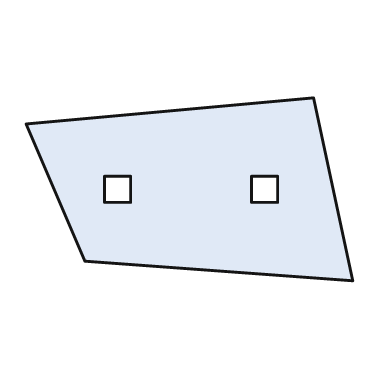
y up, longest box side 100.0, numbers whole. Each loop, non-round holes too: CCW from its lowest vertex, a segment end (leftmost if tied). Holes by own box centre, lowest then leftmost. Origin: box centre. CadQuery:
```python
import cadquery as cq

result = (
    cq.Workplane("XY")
    .moveTo(50.0, -28.0)
    .lineTo(38.0, 28.0)
    .lineTo(-50.0, 20.0)
    .lineTo(-32.0, -22.0)
    .close()
    .moveTo(-26.0, -4.0)
    .lineTo(-18.0, -4.0)
    .lineTo(-18.0, 4.0)
    .lineTo(-26.0, 4.0)
    .close()
    .moveTo(19.0, -4.0)
    .lineTo(27.0, -4.0)
    .lineTo(27.0, 4.0)
    .lineTo(19.0, 4.0)
    .close()
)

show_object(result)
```